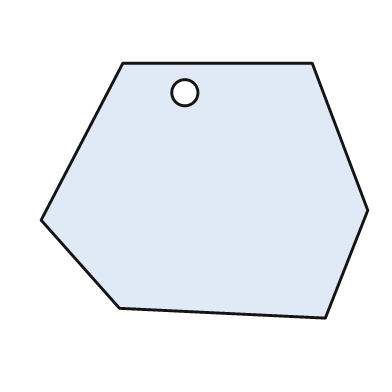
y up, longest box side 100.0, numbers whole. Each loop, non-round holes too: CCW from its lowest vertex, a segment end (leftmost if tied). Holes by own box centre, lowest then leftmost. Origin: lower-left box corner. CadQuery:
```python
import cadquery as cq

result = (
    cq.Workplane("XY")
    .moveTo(87.0, 0.0)
    .lineTo(100.0, 33.0)
    .lineTo(83.0, 78.0)
    .lineTo(25.0, 78.0)
    .lineTo(0.0, 30.0)
    .lineTo(24.0, 3.0)
    .close()
    .moveTo(44.0, 69.0)
    .circle(4.0)
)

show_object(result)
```